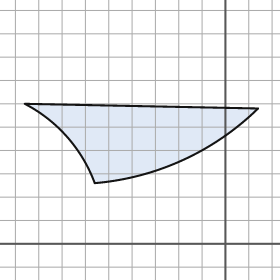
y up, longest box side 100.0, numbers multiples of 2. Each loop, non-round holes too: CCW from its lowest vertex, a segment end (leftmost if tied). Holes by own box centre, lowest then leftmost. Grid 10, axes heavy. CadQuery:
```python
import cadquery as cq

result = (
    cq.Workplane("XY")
    .moveTo(-56.0, 26.0)
    .threePointArc((-18.0, 36.0), (14.0, 58.0))
    .lineTo(-86.0, 60.0)
    .threePointArc((-68.0, 46.0), (-56.0, 26.0))
    .close()
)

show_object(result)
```